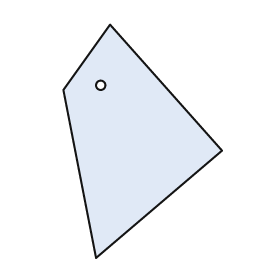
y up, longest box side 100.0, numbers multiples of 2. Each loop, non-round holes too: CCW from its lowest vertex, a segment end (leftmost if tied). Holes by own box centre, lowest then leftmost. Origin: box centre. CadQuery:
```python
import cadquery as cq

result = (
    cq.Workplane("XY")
    .moveTo(-20.0, -50.0)
    .lineTo(34.0, -4.0)
    .lineTo(-14.0, 50.0)
    .lineTo(-34.0, 22.0)
    .close()
    .moveTo(-18.0, 24.0)
    .circle(2.0)
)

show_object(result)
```